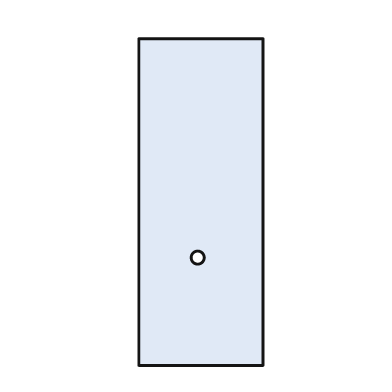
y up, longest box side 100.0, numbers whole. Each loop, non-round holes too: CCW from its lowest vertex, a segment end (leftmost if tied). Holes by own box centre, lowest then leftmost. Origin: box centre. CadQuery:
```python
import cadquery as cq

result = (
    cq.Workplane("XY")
    .moveTo(-19.0, -50.0)
    .lineTo(19.0, -50.0)
    .lineTo(19.0, 50.0)
    .lineTo(-19.0, 50.0)
    .close()
    .moveTo(-1.0, -17.0)
    .circle(2.0)
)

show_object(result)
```